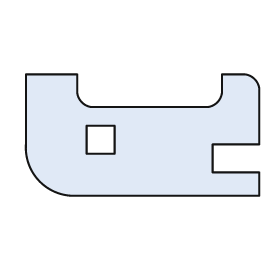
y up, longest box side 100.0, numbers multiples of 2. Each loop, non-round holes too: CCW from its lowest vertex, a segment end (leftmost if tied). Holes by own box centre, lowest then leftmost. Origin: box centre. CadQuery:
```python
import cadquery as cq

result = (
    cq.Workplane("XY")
    .moveTo(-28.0, -26.0)
    .lineTo(50.0, -26.0)
    .lineTo(50.0, -16.0)
    .lineTo(30.0, -16.0)
    .lineTo(30.0, -4.0)
    .lineTo(50.0, -4.0)
    .lineTo(50.0, 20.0)
    .threePointArc((48.0, 24.0), (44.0, 26.0))
    .lineTo(34.0, 26.0)
    .lineTo(34.0, 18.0)
    .threePointArc((32.0, 14.0), (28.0, 12.0))
    .lineTo(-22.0, 12.0)
    .threePointArc((-26.0, 14.0), (-28.0, 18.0))
    .lineTo(-28.0, 26.0)
    .lineTo(-50.0, 26.0)
    .lineTo(-50.0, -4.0)
    .threePointArc((-44.0, -20.0), (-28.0, -26.0))
    .close()
    .moveTo(-24.0, -8.0)
    .lineTo(-12.0, -8.0)
    .lineTo(-12.0, 4.0)
    .lineTo(-24.0, 4.0)
    .close()
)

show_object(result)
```